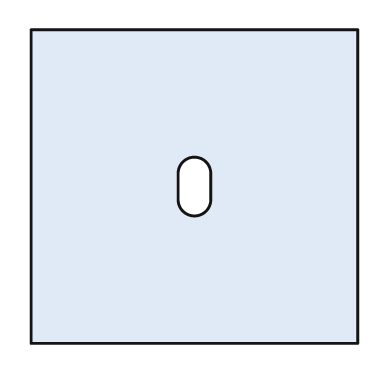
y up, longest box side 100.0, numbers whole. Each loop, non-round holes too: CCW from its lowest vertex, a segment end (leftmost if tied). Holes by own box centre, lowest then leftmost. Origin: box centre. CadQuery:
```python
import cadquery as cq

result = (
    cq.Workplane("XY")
    .moveTo(-50.0, -48.0)
    .lineTo(50.0, -48.0)
    .lineTo(50.0, 48.0)
    .lineTo(-50.0, 48.0)
    .close()
    .moveTo(-5.0, -4.0)
    .threePointArc((0.0, -9.0), (5.0, -4.0))
    .lineTo(5.0, 4.0)
    .threePointArc((0.0, 9.0), (-5.0, 4.0))
    .close()
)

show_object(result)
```